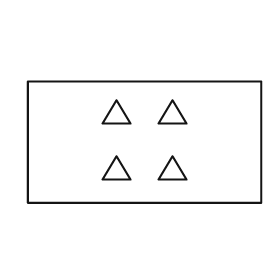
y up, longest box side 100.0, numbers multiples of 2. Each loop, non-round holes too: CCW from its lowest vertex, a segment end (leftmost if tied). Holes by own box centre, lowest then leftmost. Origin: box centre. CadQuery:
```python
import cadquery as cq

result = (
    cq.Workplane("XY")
    .moveTo(-50.0, -26.0)
    .lineTo(50.0, -26.0)
    .lineTo(50.0, 26.0)
    .lineTo(-50.0, 26.0)
    .close()
    .moveTo(-18.0, -16.0)
    .lineTo(-6.0, -16.0)
    .lineTo(-12.0, -6.0)
    .close()
    .moveTo(6.0, -16.0)
    .lineTo(18.0, -16.0)
    .lineTo(12.0, -6.0)
    .close()
    .moveTo(-18.0, 8.0)
    .lineTo(-6.0, 8.0)
    .lineTo(-12.0, 18.0)
    .close()
    .moveTo(6.0, 8.0)
    .lineTo(18.0, 8.0)
    .lineTo(12.0, 18.0)
    .close()
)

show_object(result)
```